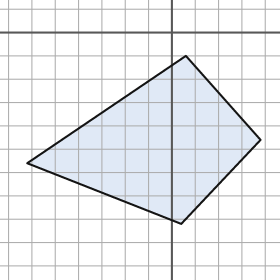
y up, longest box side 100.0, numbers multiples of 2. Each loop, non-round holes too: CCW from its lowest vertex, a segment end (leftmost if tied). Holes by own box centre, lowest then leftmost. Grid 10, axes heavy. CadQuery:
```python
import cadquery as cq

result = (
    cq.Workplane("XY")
    .moveTo(4.0, -82.0)
    .lineTo(38.0, -46.0)
    .lineTo(6.0, -10.0)
    .lineTo(-62.0, -56.0)
    .close()
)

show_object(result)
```